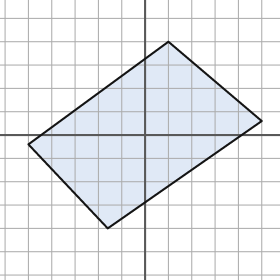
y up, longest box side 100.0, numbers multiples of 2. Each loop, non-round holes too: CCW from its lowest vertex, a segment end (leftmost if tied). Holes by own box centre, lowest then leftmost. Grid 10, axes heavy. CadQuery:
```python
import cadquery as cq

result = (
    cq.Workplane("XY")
    .moveTo(-16.0, -40.0)
    .lineTo(50.0, 6.0)
    .lineTo(10.0, 40.0)
    .lineTo(-50.0, -4.0)
    .close()
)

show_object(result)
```